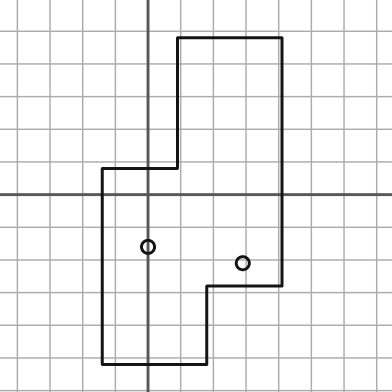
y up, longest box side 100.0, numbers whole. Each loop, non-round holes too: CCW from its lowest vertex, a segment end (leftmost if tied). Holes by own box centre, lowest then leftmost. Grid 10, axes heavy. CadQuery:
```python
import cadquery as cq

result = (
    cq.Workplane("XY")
    .moveTo(-14.0, -52.0)
    .lineTo(18.0, -52.0)
    .lineTo(18.0, -28.0)
    .lineTo(41.0, -28.0)
    .lineTo(41.0, 48.0)
    .lineTo(9.0, 48.0)
    .lineTo(9.0, 8.0)
    .lineTo(-14.0, 8.0)
    .close()
    .moveTo(29.0, -21.0)
    .circle(2.0)
    .moveTo(0.0, -16.0)
    .circle(2.0)
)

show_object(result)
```